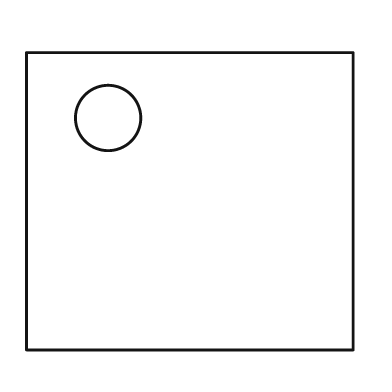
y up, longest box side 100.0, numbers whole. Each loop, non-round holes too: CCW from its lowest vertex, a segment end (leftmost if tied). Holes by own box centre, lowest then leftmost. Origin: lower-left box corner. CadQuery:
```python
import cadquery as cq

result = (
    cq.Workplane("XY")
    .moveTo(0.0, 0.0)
    .lineTo(100.0, 0.0)
    .lineTo(100.0, 91.0)
    .lineTo(0.0, 91.0)
    .close()
    .moveTo(25.0, 71.0)
    .circle(10.0)
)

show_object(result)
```